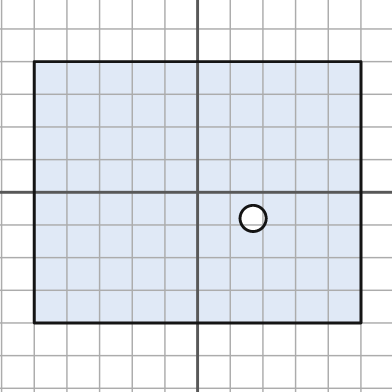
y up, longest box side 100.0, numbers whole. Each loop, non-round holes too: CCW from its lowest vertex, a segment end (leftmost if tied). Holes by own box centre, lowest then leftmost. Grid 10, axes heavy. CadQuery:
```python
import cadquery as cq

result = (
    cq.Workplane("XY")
    .moveTo(-50.0, -40.0)
    .lineTo(50.0, -40.0)
    .lineTo(50.0, 40.0)
    .lineTo(-50.0, 40.0)
    .close()
    .moveTo(17.0, -8.0)
    .circle(4.0)
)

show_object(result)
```